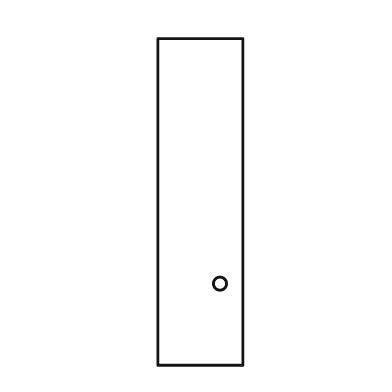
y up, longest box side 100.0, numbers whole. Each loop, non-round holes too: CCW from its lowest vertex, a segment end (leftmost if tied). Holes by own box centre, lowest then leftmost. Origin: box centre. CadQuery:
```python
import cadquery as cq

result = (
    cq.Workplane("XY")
    .moveTo(-13.0, -50.0)
    .lineTo(13.0, -50.0)
    .lineTo(13.0, 50.0)
    .lineTo(-13.0, 50.0)
    .close()
    .moveTo(6.0, -25.0)
    .circle(2.0)
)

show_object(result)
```